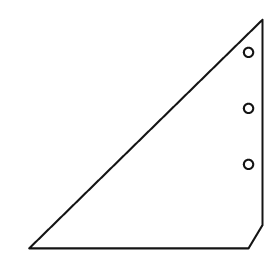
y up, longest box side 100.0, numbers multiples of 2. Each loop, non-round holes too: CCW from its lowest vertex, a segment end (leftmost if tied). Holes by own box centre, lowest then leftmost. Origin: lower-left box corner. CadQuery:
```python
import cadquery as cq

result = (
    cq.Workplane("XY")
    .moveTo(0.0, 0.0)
    .lineTo(94.0, 0.0)
    .lineTo(100.0, 10.0)
    .lineTo(100.0, 98.0)
    .close()
    .moveTo(94.0, 36.0)
    .circle(2.0)
    .moveTo(94.0, 60.0)
    .circle(2.0)
    .moveTo(94.0, 84.0)
    .circle(2.0)
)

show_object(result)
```